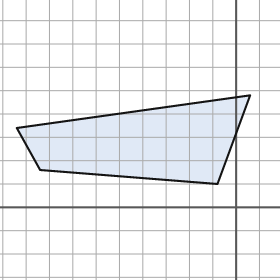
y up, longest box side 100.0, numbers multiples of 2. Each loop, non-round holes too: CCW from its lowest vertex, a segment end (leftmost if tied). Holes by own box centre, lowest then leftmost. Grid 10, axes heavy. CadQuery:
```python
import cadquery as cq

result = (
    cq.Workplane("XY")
    .moveTo(-8.0, 10.0)
    .lineTo(6.0, 48.0)
    .lineTo(-94.0, 34.0)
    .lineTo(-84.0, 16.0)
    .close()
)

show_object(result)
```